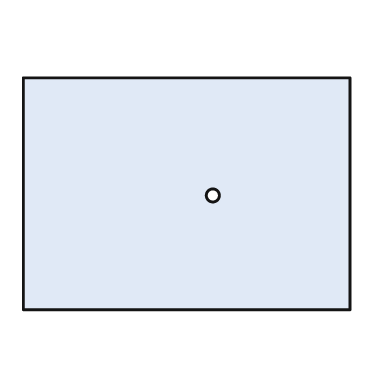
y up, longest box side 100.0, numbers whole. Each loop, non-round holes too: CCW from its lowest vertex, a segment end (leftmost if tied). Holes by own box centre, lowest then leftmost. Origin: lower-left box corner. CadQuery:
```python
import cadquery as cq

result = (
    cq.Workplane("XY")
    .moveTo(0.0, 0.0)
    .lineTo(100.0, 0.0)
    .lineTo(100.0, 71.0)
    .lineTo(0.0, 71.0)
    .close()
    .moveTo(58.0, 35.0)
    .circle(2.0)
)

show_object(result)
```